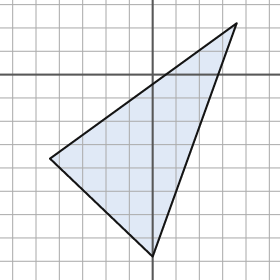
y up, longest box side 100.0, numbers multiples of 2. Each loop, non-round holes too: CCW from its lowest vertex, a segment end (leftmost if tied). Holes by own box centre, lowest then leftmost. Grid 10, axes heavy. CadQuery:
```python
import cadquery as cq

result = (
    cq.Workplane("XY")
    .moveTo(0.0, -78.0)
    .lineTo(36.0, 22.0)
    .lineTo(-44.0, -36.0)
    .close()
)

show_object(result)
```